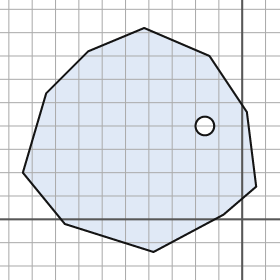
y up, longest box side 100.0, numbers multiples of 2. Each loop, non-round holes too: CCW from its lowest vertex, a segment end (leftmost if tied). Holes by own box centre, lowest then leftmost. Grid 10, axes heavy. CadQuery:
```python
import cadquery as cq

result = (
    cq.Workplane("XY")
    .moveTo(-38.0, -14.0)
    .lineTo(-8.0, 2.0)
    .lineTo(6.0, 14.0)
    .lineTo(2.0, 46.0)
    .lineTo(-14.0, 70.0)
    .lineTo(-42.0, 82.0)
    .lineTo(-66.0, 72.0)
    .lineTo(-84.0, 54.0)
    .lineTo(-94.0, 20.0)
    .lineTo(-76.0, -2.0)
    .close()
    .moveTo(-16.0, 40.0)
    .circle(4.0)
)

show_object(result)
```